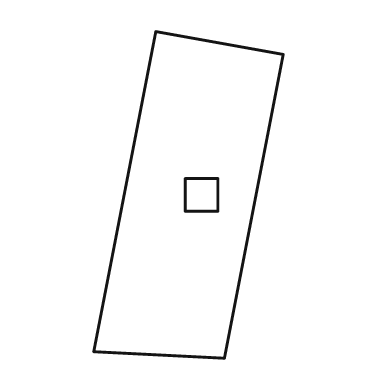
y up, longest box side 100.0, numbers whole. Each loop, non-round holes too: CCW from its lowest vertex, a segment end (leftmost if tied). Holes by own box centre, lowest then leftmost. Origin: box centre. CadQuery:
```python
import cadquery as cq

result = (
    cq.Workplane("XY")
    .moveTo(11.0, -50.0)
    .lineTo(29.0, 43.0)
    .lineTo(-10.0, 50.0)
    .lineTo(-29.0, -48.0)
    .close()
    .moveTo(-1.0, -5.0)
    .lineTo(9.0, -5.0)
    .lineTo(9.0, 5.0)
    .lineTo(-1.0, 5.0)
    .close()
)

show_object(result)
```